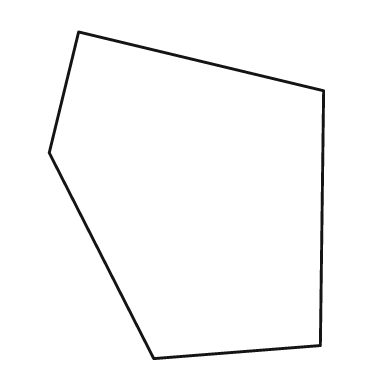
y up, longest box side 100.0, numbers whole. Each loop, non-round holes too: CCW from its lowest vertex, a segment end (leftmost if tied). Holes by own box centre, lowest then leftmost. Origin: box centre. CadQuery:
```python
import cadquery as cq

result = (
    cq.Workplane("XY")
    .moveTo(-10.0, -50.0)
    .lineTo(41.0, -46.0)
    .lineTo(42.0, 32.0)
    .lineTo(-33.0, 50.0)
    .lineTo(-42.0, 13.0)
    .close()
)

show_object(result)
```